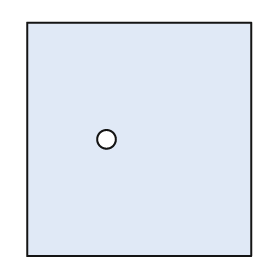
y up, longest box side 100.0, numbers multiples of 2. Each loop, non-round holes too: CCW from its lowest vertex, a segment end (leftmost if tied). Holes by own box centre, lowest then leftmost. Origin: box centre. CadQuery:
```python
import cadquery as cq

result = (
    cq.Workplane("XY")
    .moveTo(-48.0, -50.0)
    .lineTo(48.0, -50.0)
    .lineTo(48.0, 50.0)
    .lineTo(-48.0, 50.0)
    .close()
    .moveTo(-14.0, 0.0)
    .circle(4.0)
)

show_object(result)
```